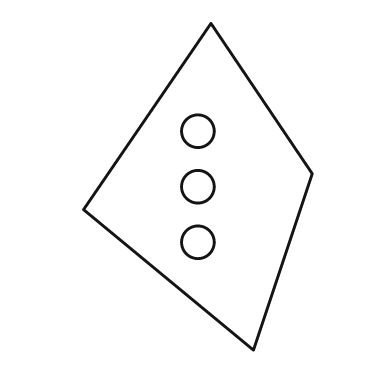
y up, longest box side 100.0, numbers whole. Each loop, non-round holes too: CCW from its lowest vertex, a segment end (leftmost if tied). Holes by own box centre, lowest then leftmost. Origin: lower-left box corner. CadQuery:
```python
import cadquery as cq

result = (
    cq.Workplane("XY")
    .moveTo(52.0, 0.0)
    .lineTo(70.0, 54.0)
    .lineTo(39.0, 100.0)
    .lineTo(0.0, 43.0)
    .close()
    .moveTo(35.0, 33.0)
    .circle(5.0)
    .moveTo(35.0, 50.0)
    .circle(5.0)
    .moveTo(35.0, 67.0)
    .circle(5.0)
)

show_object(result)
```